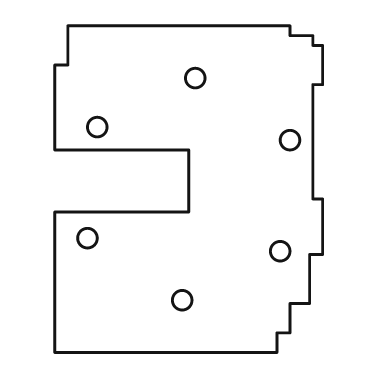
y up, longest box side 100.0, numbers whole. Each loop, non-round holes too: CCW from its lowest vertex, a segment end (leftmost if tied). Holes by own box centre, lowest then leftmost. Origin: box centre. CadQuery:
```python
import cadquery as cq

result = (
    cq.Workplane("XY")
    .moveTo(-41.0, -50.0)
    .lineTo(27.0, -50.0)
    .lineTo(27.0, -44.0)
    .lineTo(31.0, -44.0)
    .lineTo(31.0, -35.0)
    .lineTo(37.0, -35.0)
    .lineTo(37.0, -20.0)
    .lineTo(41.0, -20.0)
    .lineTo(41.0, -3.0)
    .lineTo(38.0, -3.0)
    .lineTo(38.0, 32.0)
    .lineTo(41.0, 32.0)
    .lineTo(41.0, 44.0)
    .lineTo(38.0, 44.0)
    .lineTo(38.0, 47.0)
    .lineTo(31.0, 47.0)
    .lineTo(31.0, 50.0)
    .lineTo(-37.0, 50.0)
    .lineTo(-37.0, 38.0)
    .lineTo(-41.0, 38.0)
    .lineTo(-41.0, 12.0)
    .lineTo(0.0, 12.0)
    .lineTo(0.0, -7.0)
    .lineTo(-41.0, -7.0)
    .close()
    .moveTo(-2.0, -34.0)
    .circle(3.0)
    .moveTo(28.0, -19.0)
    .circle(3.0)
    .moveTo(-31.0, -15.0)
    .circle(3.0)
    .moveTo(31.0, 15.0)
    .circle(3.0)
    .moveTo(-28.0, 19.0)
    .circle(3.0)
    .moveTo(2.0, 34.0)
    .circle(3.0)
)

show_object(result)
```